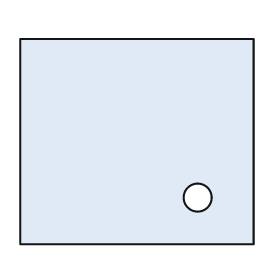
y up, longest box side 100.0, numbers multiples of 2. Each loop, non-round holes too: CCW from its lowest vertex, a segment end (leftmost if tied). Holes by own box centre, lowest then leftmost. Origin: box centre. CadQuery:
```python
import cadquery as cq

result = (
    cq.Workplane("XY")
    .moveTo(-50.0, -44.0)
    .lineTo(50.0, -44.0)
    .lineTo(50.0, 44.0)
    .lineTo(-50.0, 44.0)
    .close()
    .moveTo(26.0, -24.0)
    .circle(6.0)
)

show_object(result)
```